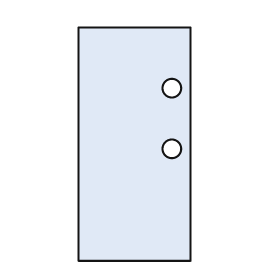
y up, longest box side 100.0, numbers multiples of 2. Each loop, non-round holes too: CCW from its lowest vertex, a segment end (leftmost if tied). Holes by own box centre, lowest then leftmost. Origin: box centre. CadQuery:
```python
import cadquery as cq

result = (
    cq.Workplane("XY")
    .moveTo(-24.0, -50.0)
    .lineTo(24.0, -50.0)
    .lineTo(24.0, 50.0)
    .lineTo(-24.0, 50.0)
    .close()
    .moveTo(16.0, -2.0)
    .circle(4.0)
    .moveTo(16.0, 24.0)
    .circle(4.0)
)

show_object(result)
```